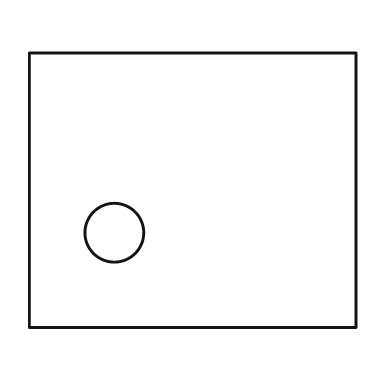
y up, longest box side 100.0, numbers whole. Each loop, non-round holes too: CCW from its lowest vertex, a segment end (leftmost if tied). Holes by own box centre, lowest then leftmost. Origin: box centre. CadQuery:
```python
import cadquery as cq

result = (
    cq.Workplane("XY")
    .moveTo(-50.0, -42.0)
    .lineTo(50.0, -42.0)
    .lineTo(50.0, 42.0)
    .lineTo(-50.0, 42.0)
    .close()
    .moveTo(-24.0, -13.0)
    .circle(9.0)
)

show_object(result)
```